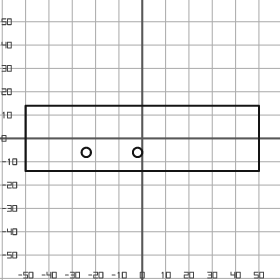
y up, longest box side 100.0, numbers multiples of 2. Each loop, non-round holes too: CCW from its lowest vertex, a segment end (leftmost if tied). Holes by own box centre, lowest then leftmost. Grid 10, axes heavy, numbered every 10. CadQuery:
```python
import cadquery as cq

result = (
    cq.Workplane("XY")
    .moveTo(-50.0, -14.0)
    .lineTo(50.0, -14.0)
    .lineTo(50.0, 14.0)
    .lineTo(-50.0, 14.0)
    .close()
    .moveTo(-24.0, -6.0)
    .circle(2.0)
    .moveTo(-2.0, -6.0)
    .circle(2.0)
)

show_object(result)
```